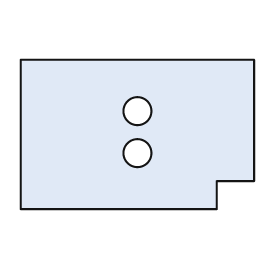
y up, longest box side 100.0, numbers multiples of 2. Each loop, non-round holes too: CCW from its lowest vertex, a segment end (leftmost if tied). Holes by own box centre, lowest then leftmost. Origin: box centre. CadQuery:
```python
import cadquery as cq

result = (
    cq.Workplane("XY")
    .moveTo(-50.0, -32.0)
    .lineTo(34.0, -32.0)
    .lineTo(34.0, -20.0)
    .lineTo(50.0, -20.0)
    .lineTo(50.0, 32.0)
    .lineTo(-50.0, 32.0)
    .close()
    .moveTo(0.0, -8.0)
    .circle(6.0)
    .moveTo(0.0, 10.0)
    .circle(6.0)
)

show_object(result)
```